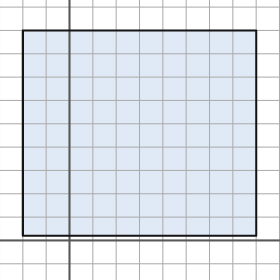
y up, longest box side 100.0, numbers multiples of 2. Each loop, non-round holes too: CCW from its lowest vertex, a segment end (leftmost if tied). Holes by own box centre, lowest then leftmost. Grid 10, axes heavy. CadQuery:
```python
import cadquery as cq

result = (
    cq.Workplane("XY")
    .moveTo(-20.0, 2.0)
    .lineTo(80.0, 2.0)
    .lineTo(80.0, 90.0)
    .lineTo(-20.0, 90.0)
    .close()
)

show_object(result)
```